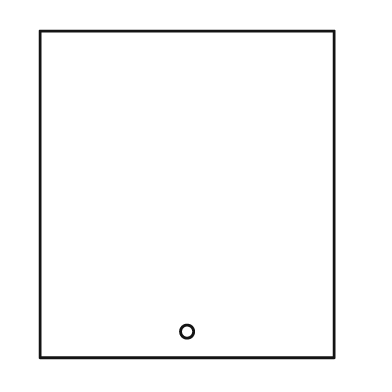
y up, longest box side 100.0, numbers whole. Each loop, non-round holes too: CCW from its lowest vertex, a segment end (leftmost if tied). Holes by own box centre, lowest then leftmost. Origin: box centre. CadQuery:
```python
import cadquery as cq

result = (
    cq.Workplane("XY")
    .moveTo(-45.0, -50.0)
    .lineTo(45.0, -50.0)
    .lineTo(45.0, 50.0)
    .lineTo(-45.0, 50.0)
    .close()
    .moveTo(0.0, -42.0)
    .circle(2.0)
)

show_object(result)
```